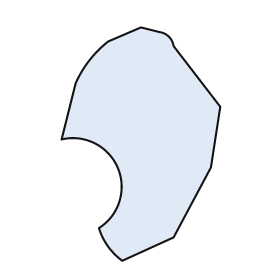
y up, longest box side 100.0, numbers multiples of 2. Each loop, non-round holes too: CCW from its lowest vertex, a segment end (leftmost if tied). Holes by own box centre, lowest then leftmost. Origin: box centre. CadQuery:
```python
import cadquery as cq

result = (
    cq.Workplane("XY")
    .moveTo(-8.0, -50.0)
    .lineTo(14.0, -40.0)
    .lineTo(30.0, -10.0)
    .lineTo(34.0, 16.0)
    .lineTo(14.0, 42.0)
    .threePointArc((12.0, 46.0), (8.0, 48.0))
    .lineTo(0.0, 50.0)
    .lineTo(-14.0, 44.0)
    .threePointArc((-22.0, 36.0), (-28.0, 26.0))
    .lineTo(-34.0, 2.0)
    .threePointArc((-10.0, -10.0), (-18.0, -36.0))
    .threePointArc((-14.0, -44.0), (-8.0, -50.0))
    .close()
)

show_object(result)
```